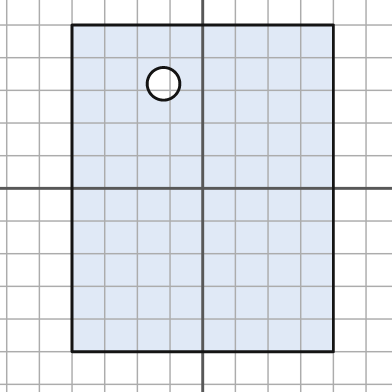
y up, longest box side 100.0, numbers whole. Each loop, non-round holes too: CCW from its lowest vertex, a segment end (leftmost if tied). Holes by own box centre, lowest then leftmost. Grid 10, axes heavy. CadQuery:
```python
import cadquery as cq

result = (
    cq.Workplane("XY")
    .moveTo(-40.0, -50.0)
    .lineTo(40.0, -50.0)
    .lineTo(40.0, 50.0)
    .lineTo(-40.0, 50.0)
    .close()
    .moveTo(-12.0, 32.0)
    .circle(5.0)
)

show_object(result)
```